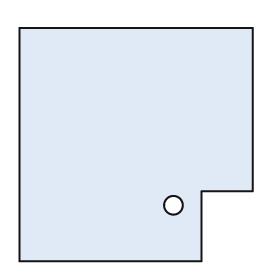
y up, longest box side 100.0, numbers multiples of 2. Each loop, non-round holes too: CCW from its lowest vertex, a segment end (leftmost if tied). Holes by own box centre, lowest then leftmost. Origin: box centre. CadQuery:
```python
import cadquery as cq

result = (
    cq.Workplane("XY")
    .moveTo(-50.0, -50.0)
    .lineTo(28.0, -50.0)
    .lineTo(28.0, -20.0)
    .lineTo(50.0, -20.0)
    .lineTo(50.0, 50.0)
    .lineTo(-50.0, 50.0)
    .close()
    .moveTo(16.0, -26.0)
    .circle(4.0)
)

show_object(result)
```